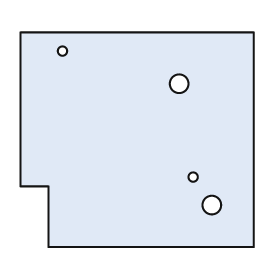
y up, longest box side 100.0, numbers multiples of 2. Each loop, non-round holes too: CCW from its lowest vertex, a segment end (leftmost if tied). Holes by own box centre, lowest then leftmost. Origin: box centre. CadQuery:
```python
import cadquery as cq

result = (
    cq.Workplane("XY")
    .moveTo(-38.0, -46.0)
    .lineTo(50.0, -46.0)
    .lineTo(50.0, 46.0)
    .lineTo(-50.0, 46.0)
    .lineTo(-50.0, -20.0)
    .lineTo(-38.0, -20.0)
    .close()
    .moveTo(32.0, -28.0)
    .circle(4.0)
    .moveTo(24.0, -16.0)
    .circle(2.0)
    .moveTo(18.0, 24.0)
    .circle(4.0)
    .moveTo(-32.0, 38.0)
    .circle(2.0)
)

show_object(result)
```